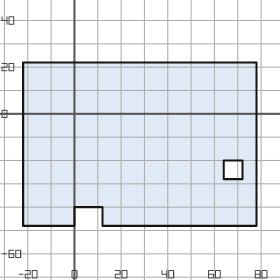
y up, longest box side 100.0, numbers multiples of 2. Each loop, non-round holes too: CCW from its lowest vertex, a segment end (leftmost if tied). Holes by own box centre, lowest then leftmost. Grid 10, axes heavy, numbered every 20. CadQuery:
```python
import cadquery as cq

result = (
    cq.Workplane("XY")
    .moveTo(-22.0, -48.0)
    .lineTo(0.0, -48.0)
    .lineTo(0.0, -40.0)
    .lineTo(12.0, -40.0)
    .lineTo(12.0, -48.0)
    .lineTo(78.0, -48.0)
    .lineTo(78.0, 22.0)
    .lineTo(-22.0, 22.0)
    .close()
    .moveTo(64.0, -28.0)
    .lineTo(72.0, -28.0)
    .lineTo(72.0, -20.0)
    .lineTo(64.0, -20.0)
    .close()
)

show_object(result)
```